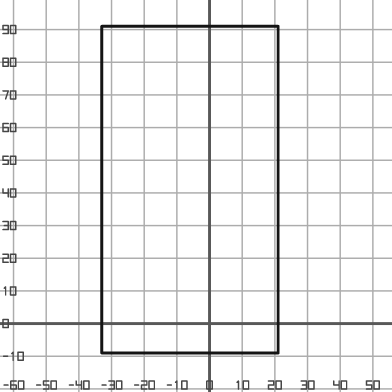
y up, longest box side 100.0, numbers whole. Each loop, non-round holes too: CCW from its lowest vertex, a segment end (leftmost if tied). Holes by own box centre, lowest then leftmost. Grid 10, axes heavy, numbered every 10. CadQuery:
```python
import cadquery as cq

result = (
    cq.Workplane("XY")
    .moveTo(-33.0, -9.0)
    .lineTo(21.0, -9.0)
    .lineTo(21.0, 91.0)
    .lineTo(-33.0, 91.0)
    .close()
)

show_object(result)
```